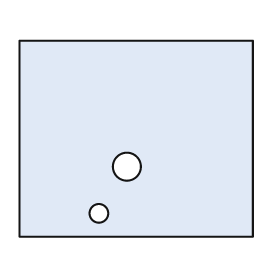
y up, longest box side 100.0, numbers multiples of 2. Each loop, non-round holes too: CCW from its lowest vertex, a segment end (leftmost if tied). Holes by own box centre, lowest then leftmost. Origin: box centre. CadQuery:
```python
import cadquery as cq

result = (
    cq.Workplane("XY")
    .moveTo(-50.0, -42.0)
    .lineTo(50.0, -42.0)
    .lineTo(50.0, 42.0)
    .lineTo(-50.0, 42.0)
    .close()
    .moveTo(-16.0, -32.0)
    .circle(4.0)
    .moveTo(-4.0, -12.0)
    .circle(6.0)
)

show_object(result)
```